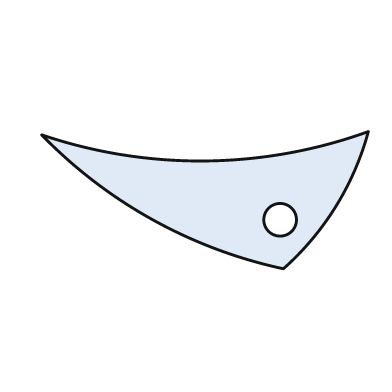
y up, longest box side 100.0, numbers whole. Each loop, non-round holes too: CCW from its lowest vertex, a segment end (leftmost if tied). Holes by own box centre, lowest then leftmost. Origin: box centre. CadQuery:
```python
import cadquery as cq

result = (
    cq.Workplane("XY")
    .moveTo(24.0, -21.0)
    .threePointArc((40.0, -2.0), (50.0, 21.0))
    .threePointArc((0.0, 12.0), (-50.0, 20.0))
    .threePointArc((-16.0, -6.0), (24.0, -21.0))
    .close()
    .moveTo(23.0, -6.0)
    .circle(5.0)
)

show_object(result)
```